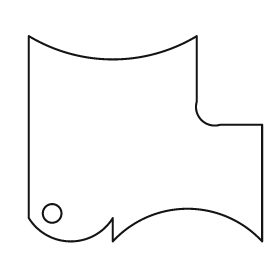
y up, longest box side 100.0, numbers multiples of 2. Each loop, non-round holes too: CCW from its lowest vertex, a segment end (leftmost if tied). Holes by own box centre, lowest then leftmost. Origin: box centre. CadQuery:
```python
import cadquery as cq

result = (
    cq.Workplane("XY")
    .moveTo(-14.0, -44.0)
    .threePointArc((18.0, -30.0), (50.0, -44.0))
    .lineTo(50.0, 6.0)
    .lineTo(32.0, 6.0)
    .threePointArc((24.0, 8.0), (22.0, 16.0))
    .lineTo(22.0, 44.0)
    .threePointArc((-14.0, 34.0), (-50.0, 44.0))
    .lineTo(-50.0, -34.0)
    .threePointArc((-32.0, -44.0), (-14.0, -34.0))
    .close()
    .moveTo(-40.0, -32.0)
    .circle(4.0)
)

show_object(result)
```